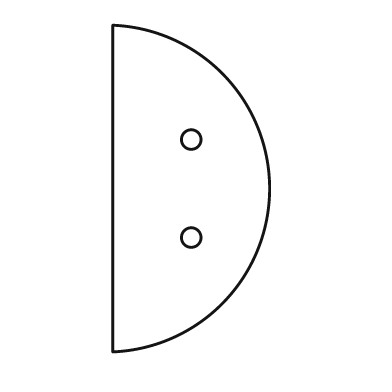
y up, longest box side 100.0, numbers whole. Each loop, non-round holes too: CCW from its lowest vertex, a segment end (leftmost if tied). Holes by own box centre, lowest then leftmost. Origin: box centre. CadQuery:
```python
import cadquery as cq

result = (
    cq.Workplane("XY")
    .moveTo(-24.0, -50.0)
    .threePointArc((24.0, 0.0), (-24.0, 50.0))
    .close()
    .moveTo(0.0, -15.0)
    .circle(3.0)
    .moveTo(0.0, 15.0)
    .circle(3.0)
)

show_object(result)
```